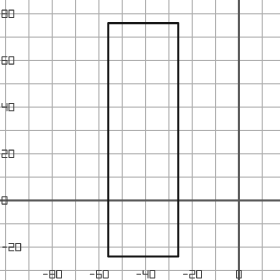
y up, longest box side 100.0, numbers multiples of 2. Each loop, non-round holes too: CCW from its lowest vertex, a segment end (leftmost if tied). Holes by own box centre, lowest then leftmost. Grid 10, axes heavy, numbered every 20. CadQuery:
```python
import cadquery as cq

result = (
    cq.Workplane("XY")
    .moveTo(-56.0, -24.0)
    .lineTo(-26.0, -24.0)
    .lineTo(-26.0, 76.0)
    .lineTo(-56.0, 76.0)
    .close()
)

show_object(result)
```